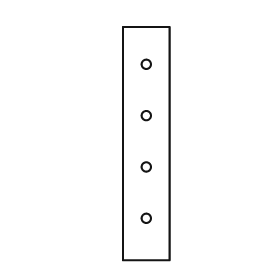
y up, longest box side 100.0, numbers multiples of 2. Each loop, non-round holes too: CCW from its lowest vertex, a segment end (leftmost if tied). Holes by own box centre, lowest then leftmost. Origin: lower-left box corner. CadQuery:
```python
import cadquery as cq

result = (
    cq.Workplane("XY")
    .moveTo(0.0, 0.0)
    .lineTo(20.0, 0.0)
    .lineTo(20.0, 100.0)
    .lineTo(0.0, 100.0)
    .close()
    .moveTo(10.0, 18.0)
    .circle(2.0)
    .moveTo(10.0, 40.0)
    .circle(2.0)
    .moveTo(10.0, 62.0)
    .circle(2.0)
    .moveTo(10.0, 84.0)
    .circle(2.0)
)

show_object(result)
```